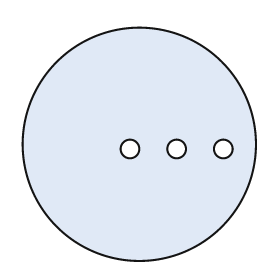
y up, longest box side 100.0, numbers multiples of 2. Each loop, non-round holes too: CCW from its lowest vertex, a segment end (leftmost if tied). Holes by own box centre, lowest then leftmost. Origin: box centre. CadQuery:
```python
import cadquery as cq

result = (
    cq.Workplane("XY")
    .moveTo(0.0, 0.0)
    .circle(50.0)
    .moveTo(-4.0, -2.0)
    .circle(4.0)
    .moveTo(16.0, -2.0)
    .circle(4.0)
    .moveTo(36.0, -2.0)
    .circle(4.0)
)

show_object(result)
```